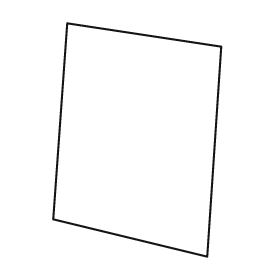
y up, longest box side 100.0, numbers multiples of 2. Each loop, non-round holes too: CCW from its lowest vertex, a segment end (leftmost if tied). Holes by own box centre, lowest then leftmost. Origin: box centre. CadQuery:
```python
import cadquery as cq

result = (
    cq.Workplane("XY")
    .moveTo(30.0, -50.0)
    .lineTo(36.0, 40.0)
    .lineTo(-30.0, 50.0)
    .lineTo(-36.0, -34.0)
    .close()
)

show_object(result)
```